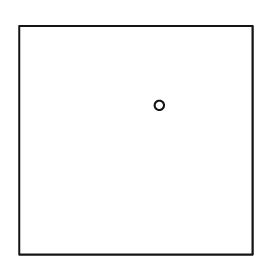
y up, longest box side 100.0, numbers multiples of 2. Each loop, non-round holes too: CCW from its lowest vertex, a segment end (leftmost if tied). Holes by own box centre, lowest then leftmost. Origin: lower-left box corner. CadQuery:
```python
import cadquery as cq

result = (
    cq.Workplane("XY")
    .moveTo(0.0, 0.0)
    .lineTo(100.0, 0.0)
    .lineTo(100.0, 98.0)
    .lineTo(0.0, 98.0)
    .close()
    .moveTo(60.0, 64.0)
    .circle(2.0)
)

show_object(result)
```